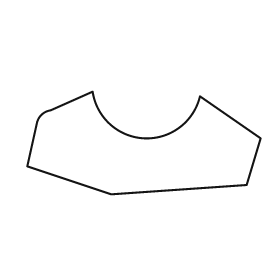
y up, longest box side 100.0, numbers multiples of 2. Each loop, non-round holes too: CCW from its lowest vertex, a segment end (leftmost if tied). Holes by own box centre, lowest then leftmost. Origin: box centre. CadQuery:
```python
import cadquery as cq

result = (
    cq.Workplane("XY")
    .moveTo(-14.0, -22.0)
    .lineTo(44.0, -18.0)
    .lineTo(50.0, 2.0)
    .lineTo(24.0, 20.0)
    .threePointArc((0.0, 2.0), (-22.0, 22.0))
    .lineTo(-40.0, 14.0)
    .threePointArc((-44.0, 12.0), (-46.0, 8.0))
    .lineTo(-50.0, -10.0)
    .close()
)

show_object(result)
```